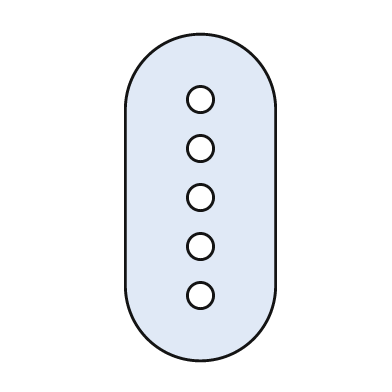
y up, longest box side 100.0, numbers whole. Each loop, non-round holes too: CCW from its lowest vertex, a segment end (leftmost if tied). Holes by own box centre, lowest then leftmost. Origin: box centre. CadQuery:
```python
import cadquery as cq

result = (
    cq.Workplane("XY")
    .moveTo(-23.0, -27.0)
    .threePointArc((0.0, -50.0), (23.0, -27.0))
    .lineTo(23.0, 27.0)
    .threePointArc((0.0, 50.0), (-23.0, 27.0))
    .close()
    .moveTo(0.0, -30.0)
    .circle(4.0)
    .moveTo(0.0, -15.0)
    .circle(4.0)
    .moveTo(0.0, 0.0)
    .circle(4.0)
    .moveTo(0.0, 15.0)
    .circle(4.0)
    .moveTo(0.0, 30.0)
    .circle(4.0)
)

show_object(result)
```